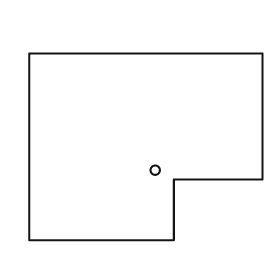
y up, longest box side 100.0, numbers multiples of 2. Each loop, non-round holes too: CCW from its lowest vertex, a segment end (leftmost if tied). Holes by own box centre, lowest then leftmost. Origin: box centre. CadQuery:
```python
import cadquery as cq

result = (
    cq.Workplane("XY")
    .moveTo(-50.0, -40.0)
    .lineTo(12.0, -40.0)
    .lineTo(12.0, -14.0)
    .lineTo(50.0, -14.0)
    .lineTo(50.0, 40.0)
    .lineTo(-50.0, 40.0)
    .close()
    .moveTo(4.0, -10.0)
    .circle(2.0)
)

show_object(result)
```